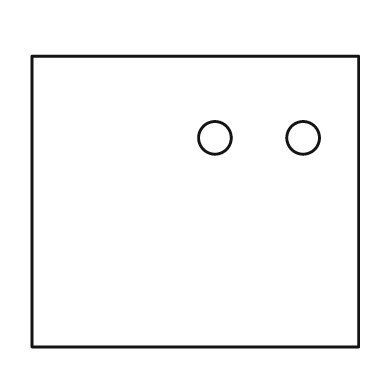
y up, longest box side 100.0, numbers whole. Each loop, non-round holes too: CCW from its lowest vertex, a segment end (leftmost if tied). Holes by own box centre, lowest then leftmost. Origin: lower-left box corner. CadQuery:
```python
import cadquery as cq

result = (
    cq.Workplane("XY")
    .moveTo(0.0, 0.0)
    .lineTo(100.0, 0.0)
    .lineTo(100.0, 89.0)
    .lineTo(0.0, 89.0)
    .close()
    .moveTo(56.0, 64.0)
    .circle(5.0)
    .moveTo(83.0, 64.0)
    .circle(5.0)
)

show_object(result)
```